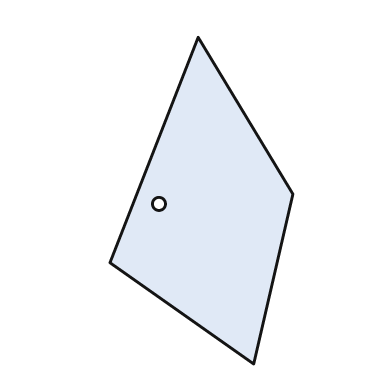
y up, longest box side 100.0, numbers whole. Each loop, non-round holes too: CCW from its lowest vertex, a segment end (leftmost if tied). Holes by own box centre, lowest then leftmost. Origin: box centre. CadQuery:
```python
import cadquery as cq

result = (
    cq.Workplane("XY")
    .moveTo(16.0, -50.0)
    .lineTo(28.0, 2.0)
    .lineTo(-1.0, 50.0)
    .lineTo(-28.0, -19.0)
    .close()
    .moveTo(-13.0, -1.0)
    .circle(2.0)
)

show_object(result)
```